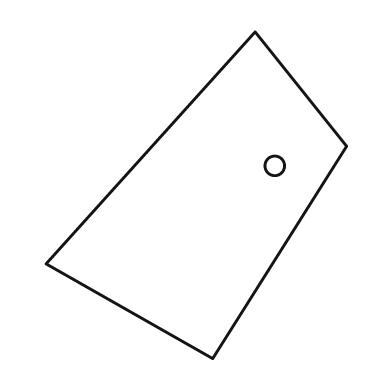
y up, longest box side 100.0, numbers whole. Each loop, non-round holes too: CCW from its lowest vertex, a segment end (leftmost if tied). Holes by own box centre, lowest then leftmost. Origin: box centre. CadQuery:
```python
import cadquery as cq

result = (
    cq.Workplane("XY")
    .moveTo(5.0, -50.0)
    .lineTo(46.0, 15.0)
    .lineTo(18.0, 50.0)
    .lineTo(-46.0, -21.0)
    .close()
    .moveTo(24.0, 9.0)
    .circle(3.0)
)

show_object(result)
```